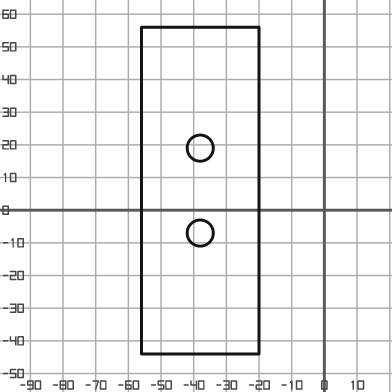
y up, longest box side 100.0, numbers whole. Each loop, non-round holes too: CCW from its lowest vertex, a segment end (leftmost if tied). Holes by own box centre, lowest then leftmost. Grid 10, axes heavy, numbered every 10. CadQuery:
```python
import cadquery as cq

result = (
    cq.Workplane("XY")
    .moveTo(-56.0, -44.0)
    .lineTo(-20.0, -44.0)
    .lineTo(-20.0, 56.0)
    .lineTo(-56.0, 56.0)
    .close()
    .moveTo(-38.0, -7.0)
    .circle(4.0)
    .moveTo(-38.0, 19.0)
    .circle(4.0)
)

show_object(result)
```